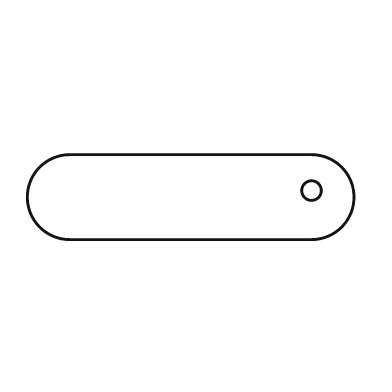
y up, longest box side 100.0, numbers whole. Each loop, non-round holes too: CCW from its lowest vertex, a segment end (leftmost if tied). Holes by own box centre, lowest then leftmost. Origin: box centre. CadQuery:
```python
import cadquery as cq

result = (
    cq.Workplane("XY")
    .moveTo(-37.0, -13.0)
    .lineTo(37.0, -13.0)
    .threePointArc((50.0, 0.0), (37.0, 13.0))
    .lineTo(-37.0, 13.0)
    .threePointArc((-50.0, 0.0), (-37.0, -13.0))
    .close()
    .moveTo(37.0, 2.0)
    .circle(3.0)
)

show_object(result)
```